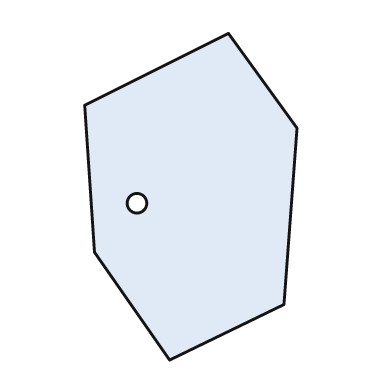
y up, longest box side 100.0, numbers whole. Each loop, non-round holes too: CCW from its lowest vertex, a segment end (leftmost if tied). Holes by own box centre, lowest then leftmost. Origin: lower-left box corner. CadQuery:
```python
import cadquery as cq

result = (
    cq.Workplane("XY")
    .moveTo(26.0, 0.0)
    .lineTo(61.0, 17.0)
    .lineTo(65.0, 71.0)
    .lineTo(44.0, 100.0)
    .lineTo(0.0, 78.0)
    .lineTo(3.0, 33.0)
    .close()
    .moveTo(16.0, 48.0)
    .circle(3.0)
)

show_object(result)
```